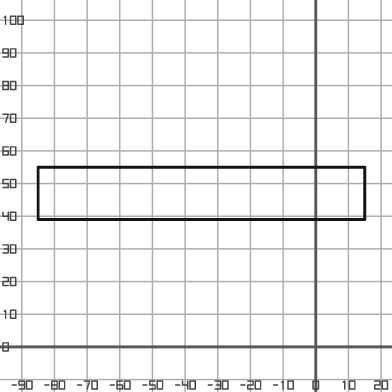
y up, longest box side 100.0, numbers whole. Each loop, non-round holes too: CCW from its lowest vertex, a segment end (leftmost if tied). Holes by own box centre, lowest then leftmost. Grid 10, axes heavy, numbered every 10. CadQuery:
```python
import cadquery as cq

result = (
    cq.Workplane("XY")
    .moveTo(-85.0, 39.0)
    .lineTo(15.0, 39.0)
    .lineTo(15.0, 55.0)
    .lineTo(-85.0, 55.0)
    .close()
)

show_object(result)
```